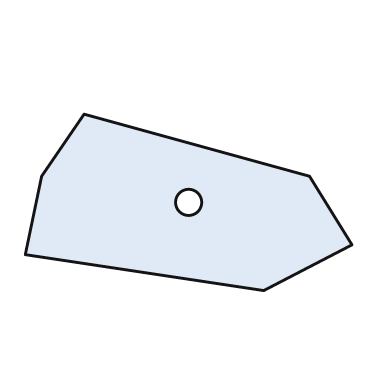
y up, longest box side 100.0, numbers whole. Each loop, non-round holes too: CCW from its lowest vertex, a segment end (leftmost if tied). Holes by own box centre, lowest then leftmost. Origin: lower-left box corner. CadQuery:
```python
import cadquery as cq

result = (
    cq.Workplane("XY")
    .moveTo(73.0, 0.0)
    .lineTo(100.0, 14.0)
    .lineTo(87.0, 35.0)
    .lineTo(18.0, 54.0)
    .lineTo(5.0, 35.0)
    .lineTo(0.0, 11.0)
    .close()
    .moveTo(50.0, 27.0)
    .circle(4.0)
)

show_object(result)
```